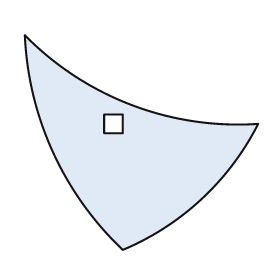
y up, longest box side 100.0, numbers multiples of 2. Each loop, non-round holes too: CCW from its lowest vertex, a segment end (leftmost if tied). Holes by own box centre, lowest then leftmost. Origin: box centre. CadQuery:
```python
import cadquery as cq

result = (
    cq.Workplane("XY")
    .moveTo(-8.0, -46.0)
    .threePointArc((26.0, -24.0), (50.0, 8.0))
    .threePointArc((-4.0, 16.0), (-50.0, 46.0))
    .threePointArc((-38.0, -4.0), (-8.0, -46.0))
    .close()
    .moveTo(-16.0, 4.0)
    .lineTo(-8.0, 4.0)
    .lineTo(-8.0, 12.0)
    .lineTo(-16.0, 12.0)
    .close()
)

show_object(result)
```